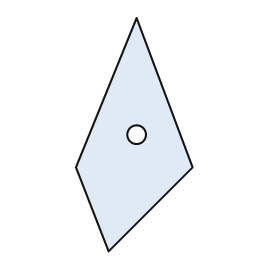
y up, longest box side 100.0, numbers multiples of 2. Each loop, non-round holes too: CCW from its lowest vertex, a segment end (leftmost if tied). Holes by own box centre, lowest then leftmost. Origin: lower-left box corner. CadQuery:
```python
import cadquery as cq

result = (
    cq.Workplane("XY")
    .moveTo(14.0, 0.0)
    .lineTo(50.0, 36.0)
    .lineTo(26.0, 100.0)
    .lineTo(0.0, 36.0)
    .close()
    .moveTo(26.0, 50.0)
    .circle(4.0)
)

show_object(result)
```